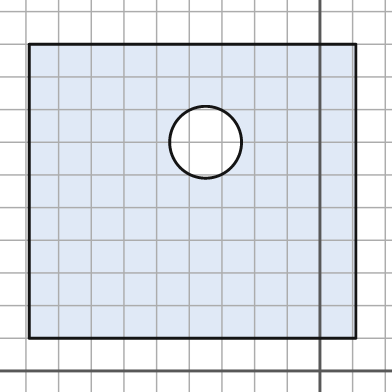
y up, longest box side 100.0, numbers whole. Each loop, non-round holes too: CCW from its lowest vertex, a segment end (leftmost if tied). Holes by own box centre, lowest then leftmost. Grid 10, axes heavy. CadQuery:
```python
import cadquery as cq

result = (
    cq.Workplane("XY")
    .moveTo(-89.0, 10.0)
    .lineTo(11.0, 10.0)
    .lineTo(11.0, 100.0)
    .lineTo(-89.0, 100.0)
    .close()
    .moveTo(-35.0, 70.0)
    .circle(11.0)
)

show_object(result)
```